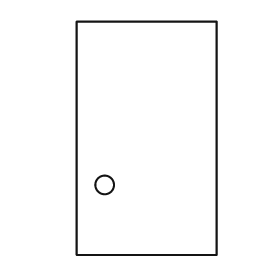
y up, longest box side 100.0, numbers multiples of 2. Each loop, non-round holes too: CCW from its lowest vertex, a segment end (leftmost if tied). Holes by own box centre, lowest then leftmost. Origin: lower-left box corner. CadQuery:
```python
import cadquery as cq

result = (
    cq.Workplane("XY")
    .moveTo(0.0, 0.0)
    .lineTo(60.0, 0.0)
    .lineTo(60.0, 100.0)
    .lineTo(0.0, 100.0)
    .close()
    .moveTo(12.0, 30.0)
    .circle(4.0)
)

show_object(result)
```